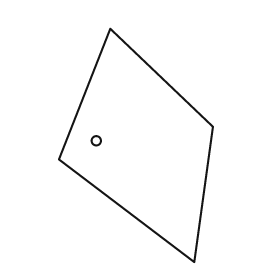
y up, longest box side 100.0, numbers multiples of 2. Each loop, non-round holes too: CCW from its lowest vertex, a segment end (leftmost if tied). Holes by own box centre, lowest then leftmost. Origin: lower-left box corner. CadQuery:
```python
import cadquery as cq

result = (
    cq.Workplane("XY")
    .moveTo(58.0, 0.0)
    .lineTo(66.0, 58.0)
    .lineTo(22.0, 100.0)
    .lineTo(0.0, 44.0)
    .close()
    .moveTo(16.0, 52.0)
    .circle(2.0)
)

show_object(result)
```